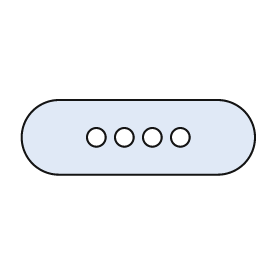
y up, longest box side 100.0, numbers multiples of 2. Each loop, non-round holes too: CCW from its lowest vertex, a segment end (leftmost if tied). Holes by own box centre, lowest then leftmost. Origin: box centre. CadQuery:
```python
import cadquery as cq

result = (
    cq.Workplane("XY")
    .moveTo(-34.0, -16.0)
    .lineTo(34.0, -16.0)
    .threePointArc((50.0, 0.0), (34.0, 16.0))
    .lineTo(-34.0, 16.0)
    .threePointArc((-50.0, 0.0), (-34.0, -16.0))
    .close()
    .moveTo(-18.0, 0.0)
    .circle(4.0)
    .moveTo(-6.0, 0.0)
    .circle(4.0)
    .moveTo(6.0, 0.0)
    .circle(4.0)
    .moveTo(18.0, 0.0)
    .circle(4.0)
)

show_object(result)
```